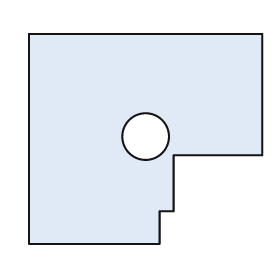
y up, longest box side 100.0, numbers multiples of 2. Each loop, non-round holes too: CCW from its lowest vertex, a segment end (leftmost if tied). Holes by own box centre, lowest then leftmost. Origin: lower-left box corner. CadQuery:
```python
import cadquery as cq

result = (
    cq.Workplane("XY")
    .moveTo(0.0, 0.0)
    .lineTo(56.0, 0.0)
    .lineTo(56.0, 14.0)
    .lineTo(62.0, 14.0)
    .lineTo(62.0, 38.0)
    .lineTo(100.0, 38.0)
    .lineTo(100.0, 90.0)
    .lineTo(0.0, 90.0)
    .close()
    .moveTo(50.0, 46.0)
    .circle(10.0)
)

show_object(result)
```